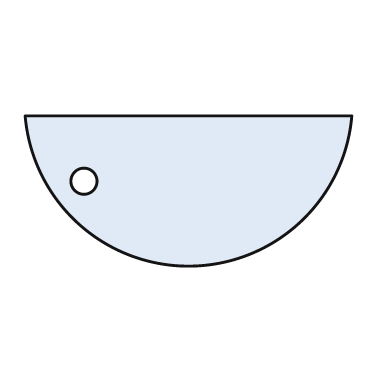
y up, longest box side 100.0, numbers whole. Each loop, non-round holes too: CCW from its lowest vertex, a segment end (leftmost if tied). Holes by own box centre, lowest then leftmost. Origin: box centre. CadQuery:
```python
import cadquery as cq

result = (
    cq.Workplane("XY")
    .moveTo(-50.0, 23.0)
    .threePointArc((0.0, -23.0), (50.0, 23.0))
    .close()
    .moveTo(-32.0, 3.0)
    .circle(4.0)
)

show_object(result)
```